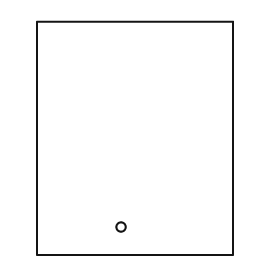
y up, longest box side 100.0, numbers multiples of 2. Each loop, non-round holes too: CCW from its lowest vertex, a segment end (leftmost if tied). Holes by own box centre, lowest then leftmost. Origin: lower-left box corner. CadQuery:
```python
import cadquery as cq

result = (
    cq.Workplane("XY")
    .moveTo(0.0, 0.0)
    .lineTo(84.0, 0.0)
    .lineTo(84.0, 100.0)
    .lineTo(0.0, 100.0)
    .close()
    .moveTo(36.0, 12.0)
    .circle(2.0)
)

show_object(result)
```